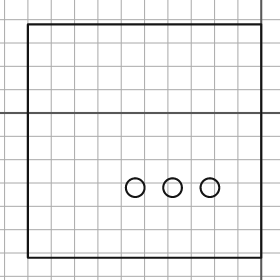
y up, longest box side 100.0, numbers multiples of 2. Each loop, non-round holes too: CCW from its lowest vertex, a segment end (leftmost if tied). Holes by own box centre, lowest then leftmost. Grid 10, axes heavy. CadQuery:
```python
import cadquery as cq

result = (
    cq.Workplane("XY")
    .moveTo(-100.0, -62.0)
    .lineTo(0.0, -62.0)
    .lineTo(0.0, 38.0)
    .lineTo(-100.0, 38.0)
    .close()
    .moveTo(-54.0, -32.0)
    .circle(4.0)
    .moveTo(-38.0, -32.0)
    .circle(4.0)
    .moveTo(-22.0, -32.0)
    .circle(4.0)
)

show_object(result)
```